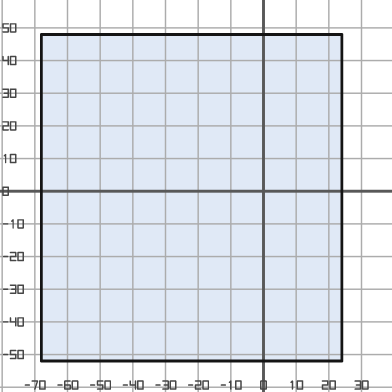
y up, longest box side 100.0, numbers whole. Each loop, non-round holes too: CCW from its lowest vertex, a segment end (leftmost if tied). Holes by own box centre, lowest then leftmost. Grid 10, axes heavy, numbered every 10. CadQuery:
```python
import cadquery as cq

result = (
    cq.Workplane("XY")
    .moveTo(-68.0, -52.0)
    .lineTo(24.0, -52.0)
    .lineTo(24.0, 48.0)
    .lineTo(-68.0, 48.0)
    .close()
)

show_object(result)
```